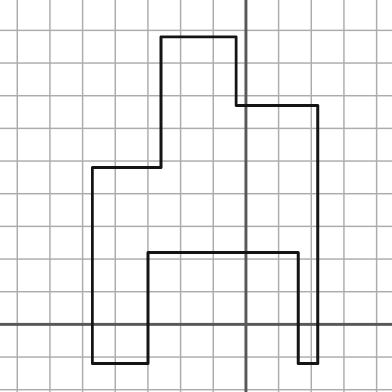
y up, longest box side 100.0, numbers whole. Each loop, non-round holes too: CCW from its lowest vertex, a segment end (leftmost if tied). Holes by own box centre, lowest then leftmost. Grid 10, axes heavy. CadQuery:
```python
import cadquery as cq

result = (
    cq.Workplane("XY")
    .moveTo(-47.0, -12.0)
    .lineTo(-30.0, -12.0)
    .lineTo(-30.0, 22.0)
    .lineTo(16.0, 22.0)
    .lineTo(16.0, -12.0)
    .lineTo(22.0, -12.0)
    .lineTo(22.0, 67.0)
    .lineTo(-3.0, 67.0)
    .lineTo(-3.0, 88.0)
    .lineTo(-26.0, 88.0)
    .lineTo(-26.0, 48.0)
    .lineTo(-47.0, 48.0)
    .close()
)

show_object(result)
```